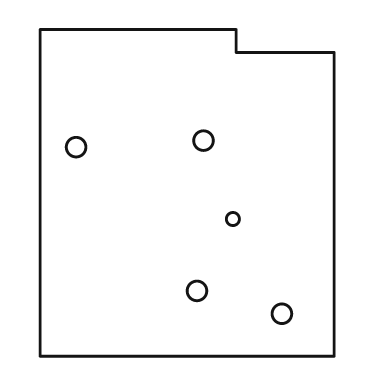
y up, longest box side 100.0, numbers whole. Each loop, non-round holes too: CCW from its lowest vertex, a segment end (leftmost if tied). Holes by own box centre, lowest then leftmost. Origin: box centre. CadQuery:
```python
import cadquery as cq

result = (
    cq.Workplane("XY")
    .moveTo(-45.0, -50.0)
    .lineTo(45.0, -50.0)
    .lineTo(45.0, 43.0)
    .lineTo(15.0, 43.0)
    .lineTo(15.0, 50.0)
    .lineTo(-45.0, 50.0)
    .close()
    .moveTo(29.0, -37.0)
    .circle(3.0)
    .moveTo(3.0, -30.0)
    .circle(3.0)
    .moveTo(14.0, -8.0)
    .circle(2.0)
    .moveTo(-34.0, 14.0)
    .circle(3.0)
    .moveTo(5.0, 16.0)
    .circle(3.0)
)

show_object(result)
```